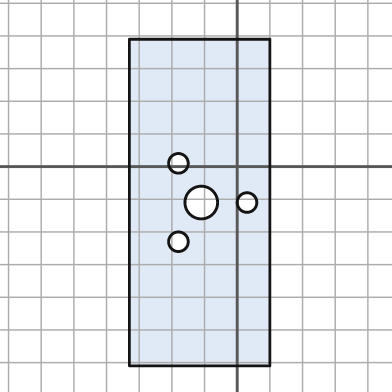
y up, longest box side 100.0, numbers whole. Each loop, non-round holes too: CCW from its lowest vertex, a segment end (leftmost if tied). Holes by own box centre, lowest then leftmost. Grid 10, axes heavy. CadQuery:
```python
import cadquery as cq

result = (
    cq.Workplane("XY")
    .moveTo(-33.0, -61.0)
    .lineTo(10.0, -61.0)
    .lineTo(10.0, 39.0)
    .lineTo(-33.0, 39.0)
    .close()
    .moveTo(-18.0, -23.0)
    .circle(3.0)
    .moveTo(-11.0, -11.0)
    .circle(5.0)
    .moveTo(3.0, -11.0)
    .circle(3.0)
    .moveTo(-18.0, 1.0)
    .circle(3.0)
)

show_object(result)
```